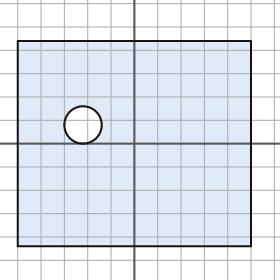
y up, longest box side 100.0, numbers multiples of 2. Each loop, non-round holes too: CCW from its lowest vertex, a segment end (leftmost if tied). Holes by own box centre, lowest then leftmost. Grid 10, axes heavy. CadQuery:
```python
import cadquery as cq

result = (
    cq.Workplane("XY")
    .moveTo(-50.0, -44.0)
    .lineTo(50.0, -44.0)
    .lineTo(50.0, 44.0)
    .lineTo(-50.0, 44.0)
    .close()
    .moveTo(-22.0, 8.0)
    .circle(8.0)
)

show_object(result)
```